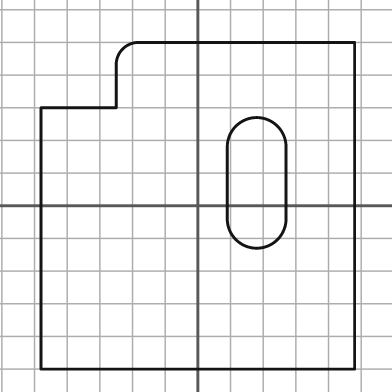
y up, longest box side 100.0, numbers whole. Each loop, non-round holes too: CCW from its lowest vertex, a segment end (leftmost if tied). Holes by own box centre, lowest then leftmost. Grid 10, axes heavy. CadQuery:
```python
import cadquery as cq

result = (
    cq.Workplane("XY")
    .moveTo(-48.0, -50.0)
    .lineTo(48.0, -50.0)
    .lineTo(48.0, 50.0)
    .lineTo(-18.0, 50.0)
    .threePointArc((-23.0, 48.0), (-25.0, 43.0))
    .lineTo(-25.0, 30.0)
    .lineTo(-48.0, 30.0)
    .close()
    .moveTo(9.0, -4.0)
    .threePointArc((18.0, -13.0), (27.0, -4.0))
    .lineTo(27.0, 18.0)
    .threePointArc((18.0, 27.0), (9.0, 18.0))
    .close()
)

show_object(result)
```